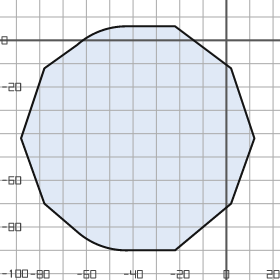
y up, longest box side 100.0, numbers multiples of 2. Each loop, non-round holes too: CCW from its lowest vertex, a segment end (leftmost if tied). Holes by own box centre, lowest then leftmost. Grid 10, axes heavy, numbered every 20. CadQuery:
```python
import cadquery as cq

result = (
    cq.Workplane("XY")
    .moveTo(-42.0, -90.0)
    .lineTo(-22.0, -90.0)
    .lineTo(2.0, -70.0)
    .lineTo(12.0, -42.0)
    .lineTo(2.0, -12.0)
    .lineTo(-22.0, 6.0)
    .lineTo(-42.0, 6.0)
    .threePointArc((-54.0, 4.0), (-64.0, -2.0))
    .lineTo(-78.0, -12.0)
    .lineTo(-88.0, -42.0)
    .lineTo(-78.0, -70.0)
    .lineTo(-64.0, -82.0)
    .threePointArc((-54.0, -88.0), (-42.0, -90.0))
    .close()
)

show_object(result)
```